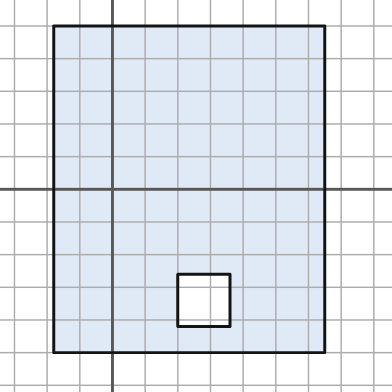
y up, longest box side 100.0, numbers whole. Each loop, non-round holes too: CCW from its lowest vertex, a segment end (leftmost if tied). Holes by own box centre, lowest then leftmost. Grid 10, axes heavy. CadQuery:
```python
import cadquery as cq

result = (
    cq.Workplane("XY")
    .moveTo(-18.0, -50.0)
    .lineTo(65.0, -50.0)
    .lineTo(65.0, 50.0)
    .lineTo(-18.0, 50.0)
    .close()
    .moveTo(20.0, -42.0)
    .lineTo(36.0, -42.0)
    .lineTo(36.0, -26.0)
    .lineTo(20.0, -26.0)
    .close()
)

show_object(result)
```